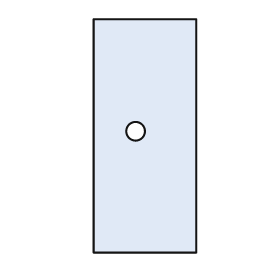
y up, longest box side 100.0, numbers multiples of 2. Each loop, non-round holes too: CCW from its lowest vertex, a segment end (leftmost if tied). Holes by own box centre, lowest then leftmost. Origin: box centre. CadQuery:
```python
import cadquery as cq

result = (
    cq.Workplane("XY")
    .moveTo(-22.0, -50.0)
    .lineTo(22.0, -50.0)
    .lineTo(22.0, 50.0)
    .lineTo(-22.0, 50.0)
    .close()
    .moveTo(-4.0, 2.0)
    .circle(4.0)
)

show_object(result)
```